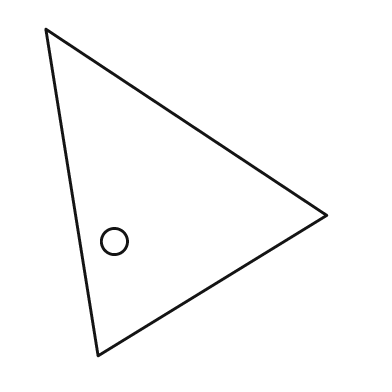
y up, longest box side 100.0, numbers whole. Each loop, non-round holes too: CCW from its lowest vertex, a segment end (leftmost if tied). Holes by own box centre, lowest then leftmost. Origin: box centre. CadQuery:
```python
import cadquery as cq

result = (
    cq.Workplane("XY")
    .moveTo(-27.0, -50.0)
    .lineTo(43.0, -7.0)
    .lineTo(-43.0, 50.0)
    .close()
    .moveTo(-22.0, -15.0)
    .circle(4.0)
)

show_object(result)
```